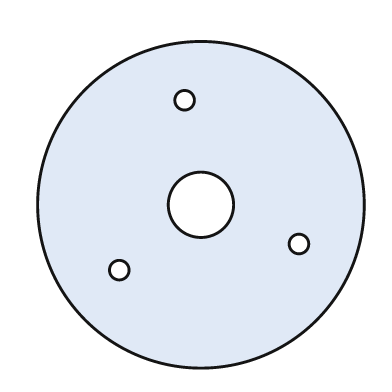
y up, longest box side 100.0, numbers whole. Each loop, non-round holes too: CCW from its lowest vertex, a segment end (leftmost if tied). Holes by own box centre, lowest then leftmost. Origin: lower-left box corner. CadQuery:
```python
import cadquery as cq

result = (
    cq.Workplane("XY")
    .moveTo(50.0, 50.0)
    .circle(50.0)
    .moveTo(25.0, 30.0)
    .circle(3.0)
    .moveTo(80.0, 38.0)
    .circle(3.0)
    .moveTo(50.0, 50.0)
    .circle(10.0)
    .moveTo(45.0, 82.0)
    .circle(3.0)
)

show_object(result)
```